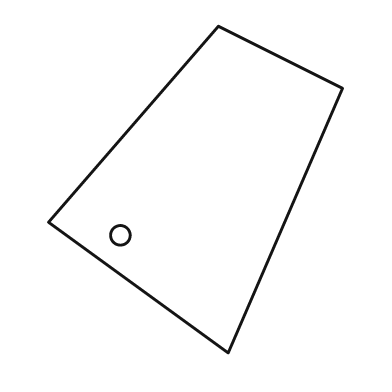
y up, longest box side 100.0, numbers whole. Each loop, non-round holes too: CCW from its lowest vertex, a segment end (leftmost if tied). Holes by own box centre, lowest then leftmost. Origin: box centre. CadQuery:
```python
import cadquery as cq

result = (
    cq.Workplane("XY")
    .moveTo(10.0, -50.0)
    .lineTo(45.0, 31.0)
    .lineTo(7.0, 50.0)
    .lineTo(-45.0, -10.0)
    .close()
    .moveTo(-23.0, -14.0)
    .circle(3.0)
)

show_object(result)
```